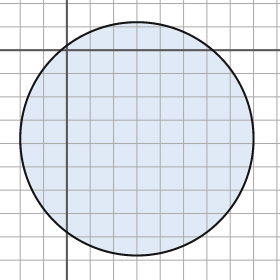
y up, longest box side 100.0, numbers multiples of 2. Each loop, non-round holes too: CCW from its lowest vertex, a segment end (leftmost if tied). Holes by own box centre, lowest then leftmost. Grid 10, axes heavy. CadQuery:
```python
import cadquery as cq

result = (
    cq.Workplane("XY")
    .moveTo(30.0, -38.0)
    .circle(50.0)
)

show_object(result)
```